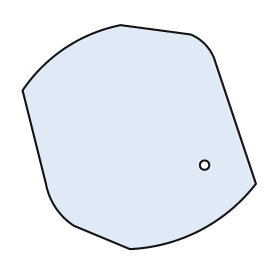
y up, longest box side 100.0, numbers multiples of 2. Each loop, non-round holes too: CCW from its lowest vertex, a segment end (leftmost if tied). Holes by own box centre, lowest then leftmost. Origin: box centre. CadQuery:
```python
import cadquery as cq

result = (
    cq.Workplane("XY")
    .moveTo(-4.0, -48.0)
    .threePointArc((26.0, -40.0), (50.0, -20.0))
    .lineTo(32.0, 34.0)
    .threePointArc((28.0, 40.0), (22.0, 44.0))
    .lineTo(-8.0, 48.0)
    .threePointArc((-32.0, 38.0), (-50.0, 20.0))
    .lineTo(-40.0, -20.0)
    .threePointArc((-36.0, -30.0), (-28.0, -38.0))
    .close()
    .moveTo(28.0, -12.0)
    .circle(2.0)
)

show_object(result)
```